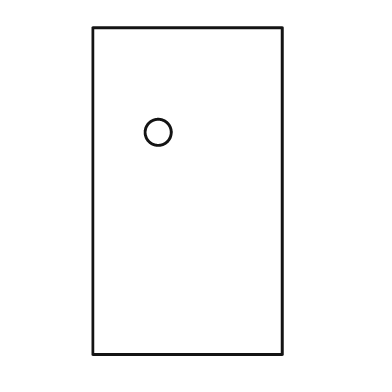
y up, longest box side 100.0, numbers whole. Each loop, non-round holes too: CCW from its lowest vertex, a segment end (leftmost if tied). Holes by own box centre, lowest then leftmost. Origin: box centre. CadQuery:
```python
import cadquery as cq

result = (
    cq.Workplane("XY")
    .moveTo(-29.0, -50.0)
    .lineTo(29.0, -50.0)
    .lineTo(29.0, 50.0)
    .lineTo(-29.0, 50.0)
    .close()
    .moveTo(-9.0, 18.0)
    .circle(4.0)
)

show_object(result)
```